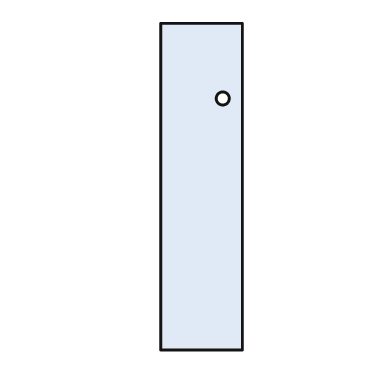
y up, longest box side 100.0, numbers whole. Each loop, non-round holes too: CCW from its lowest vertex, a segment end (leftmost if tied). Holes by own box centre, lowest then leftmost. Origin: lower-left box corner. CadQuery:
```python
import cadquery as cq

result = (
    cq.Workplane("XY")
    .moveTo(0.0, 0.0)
    .lineTo(25.0, 0.0)
    .lineTo(25.0, 100.0)
    .lineTo(0.0, 100.0)
    .close()
    .moveTo(19.0, 77.0)
    .circle(2.0)
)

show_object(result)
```